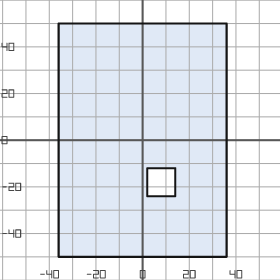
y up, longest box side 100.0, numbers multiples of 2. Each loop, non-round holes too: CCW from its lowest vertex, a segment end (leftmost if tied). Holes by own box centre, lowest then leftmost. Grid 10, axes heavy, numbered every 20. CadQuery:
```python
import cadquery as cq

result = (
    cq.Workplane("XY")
    .moveTo(-36.0, -50.0)
    .lineTo(36.0, -50.0)
    .lineTo(36.0, 50.0)
    .lineTo(-36.0, 50.0)
    .close()
    .moveTo(2.0, -24.0)
    .lineTo(14.0, -24.0)
    .lineTo(14.0, -12.0)
    .lineTo(2.0, -12.0)
    .close()
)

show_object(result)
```